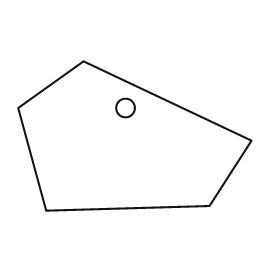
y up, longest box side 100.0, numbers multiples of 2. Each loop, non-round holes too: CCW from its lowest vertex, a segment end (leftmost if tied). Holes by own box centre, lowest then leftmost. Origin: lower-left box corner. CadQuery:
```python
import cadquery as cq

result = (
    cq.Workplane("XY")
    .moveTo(12.0, 0.0)
    .lineTo(82.0, 2.0)
    .lineTo(100.0, 30.0)
    .lineTo(28.0, 64.0)
    .lineTo(0.0, 44.0)
    .close()
    .moveTo(46.0, 44.0)
    .circle(4.0)
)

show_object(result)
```